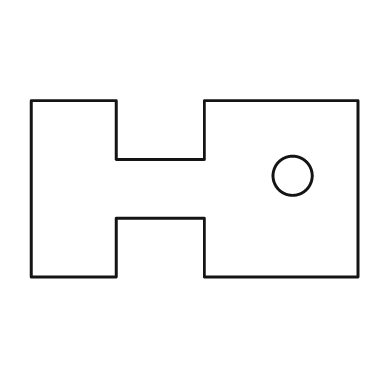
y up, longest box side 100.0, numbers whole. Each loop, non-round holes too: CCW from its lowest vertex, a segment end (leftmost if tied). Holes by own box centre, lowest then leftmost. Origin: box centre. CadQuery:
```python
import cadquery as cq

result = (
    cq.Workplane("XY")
    .moveTo(-50.0, -27.0)
    .lineTo(-24.0, -27.0)
    .lineTo(-24.0, -9.0)
    .lineTo(3.0, -9.0)
    .lineTo(3.0, -27.0)
    .lineTo(50.0, -27.0)
    .lineTo(50.0, 27.0)
    .lineTo(3.0, 27.0)
    .lineTo(3.0, 9.0)
    .lineTo(-24.0, 9.0)
    .lineTo(-24.0, 27.0)
    .lineTo(-50.0, 27.0)
    .close()
    .moveTo(30.0, 4.0)
    .circle(6.0)
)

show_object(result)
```